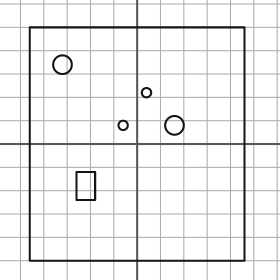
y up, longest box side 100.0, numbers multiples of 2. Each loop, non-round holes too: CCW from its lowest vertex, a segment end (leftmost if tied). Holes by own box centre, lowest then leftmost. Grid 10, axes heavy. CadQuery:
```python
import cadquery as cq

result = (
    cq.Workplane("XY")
    .moveTo(-46.0, -50.0)
    .lineTo(46.0, -50.0)
    .lineTo(46.0, 50.0)
    .lineTo(-46.0, 50.0)
    .close()
    .moveTo(-26.0, -24.0)
    .lineTo(-18.0, -24.0)
    .lineTo(-18.0, -12.0)
    .lineTo(-26.0, -12.0)
    .close()
    .moveTo(-6.0, 8.0)
    .circle(2.0)
    .moveTo(16.0, 8.0)
    .circle(4.0)
    .moveTo(4.0, 22.0)
    .circle(2.0)
    .moveTo(-32.0, 34.0)
    .circle(4.0)
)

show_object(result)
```